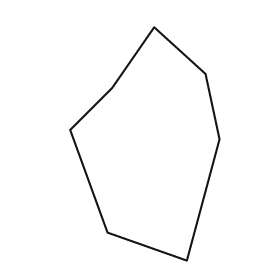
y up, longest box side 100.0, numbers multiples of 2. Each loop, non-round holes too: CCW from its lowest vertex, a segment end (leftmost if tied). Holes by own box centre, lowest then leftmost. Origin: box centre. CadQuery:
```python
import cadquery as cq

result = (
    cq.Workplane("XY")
    .moveTo(18.0, -50.0)
    .lineTo(32.0, 2.0)
    .lineTo(26.0, 30.0)
    .lineTo(4.0, 50.0)
    .lineTo(-14.0, 24.0)
    .lineTo(-32.0, 6.0)
    .lineTo(-16.0, -38.0)
    .close()
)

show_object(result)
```